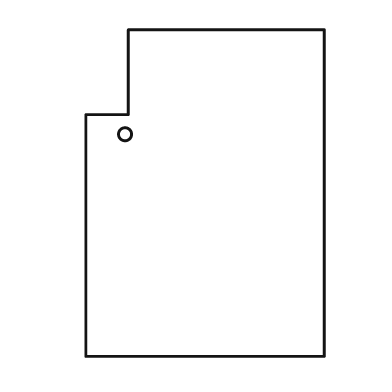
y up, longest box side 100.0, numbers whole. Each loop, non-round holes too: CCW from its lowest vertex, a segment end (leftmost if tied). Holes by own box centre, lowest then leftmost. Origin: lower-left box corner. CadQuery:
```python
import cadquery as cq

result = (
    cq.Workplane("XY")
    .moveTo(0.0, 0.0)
    .lineTo(73.0, 0.0)
    .lineTo(73.0, 100.0)
    .lineTo(13.0, 100.0)
    .lineTo(13.0, 74.0)
    .lineTo(0.0, 74.0)
    .close()
    .moveTo(12.0, 68.0)
    .circle(2.0)
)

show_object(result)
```